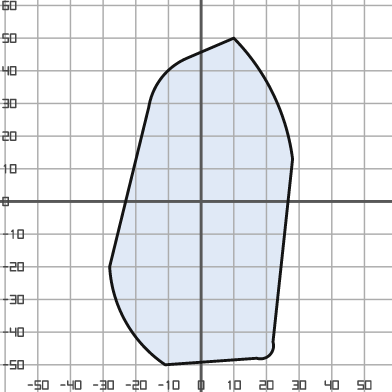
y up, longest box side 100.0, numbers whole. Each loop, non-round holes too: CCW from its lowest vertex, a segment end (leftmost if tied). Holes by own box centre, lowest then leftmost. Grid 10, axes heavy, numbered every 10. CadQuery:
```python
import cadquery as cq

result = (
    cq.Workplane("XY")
    .moveTo(-11.0, -50.0)
    .lineTo(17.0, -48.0)
    .threePointArc((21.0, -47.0), (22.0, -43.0))
    .lineTo(28.0, 13.0)
    .threePointArc((22.0, 33.0), (10.0, 50.0))
    .lineTo(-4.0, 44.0)
    .threePointArc((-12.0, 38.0), (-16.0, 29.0))
    .lineTo(-28.0, -20.0)
    .threePointArc((-23.0, -37.0), (-11.0, -50.0))
    .close()
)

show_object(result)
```